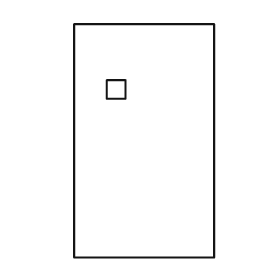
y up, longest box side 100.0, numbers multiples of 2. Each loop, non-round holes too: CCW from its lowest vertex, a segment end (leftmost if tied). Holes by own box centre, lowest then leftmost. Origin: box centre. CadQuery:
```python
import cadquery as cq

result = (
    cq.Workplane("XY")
    .moveTo(-30.0, -50.0)
    .lineTo(30.0, -50.0)
    .lineTo(30.0, 50.0)
    .lineTo(-30.0, 50.0)
    .close()
    .moveTo(-16.0, 18.0)
    .lineTo(-8.0, 18.0)
    .lineTo(-8.0, 26.0)
    .lineTo(-16.0, 26.0)
    .close()
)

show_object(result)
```